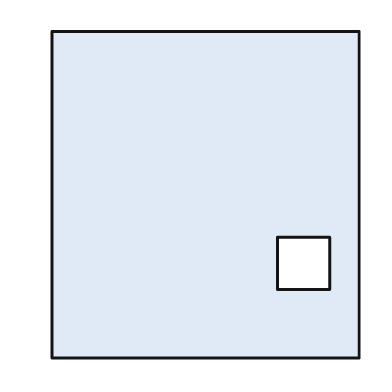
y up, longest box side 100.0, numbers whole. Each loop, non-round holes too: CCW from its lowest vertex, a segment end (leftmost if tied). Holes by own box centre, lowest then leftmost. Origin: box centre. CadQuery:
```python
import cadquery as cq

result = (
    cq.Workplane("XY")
    .moveTo(-47.0, -50.0)
    .lineTo(47.0, -50.0)
    .lineTo(47.0, 50.0)
    .lineTo(-47.0, 50.0)
    .close()
    .moveTo(22.0, -29.0)
    .lineTo(38.0, -29.0)
    .lineTo(38.0, -13.0)
    .lineTo(22.0, -13.0)
    .close()
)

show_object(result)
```